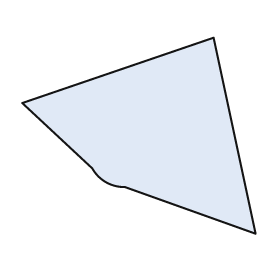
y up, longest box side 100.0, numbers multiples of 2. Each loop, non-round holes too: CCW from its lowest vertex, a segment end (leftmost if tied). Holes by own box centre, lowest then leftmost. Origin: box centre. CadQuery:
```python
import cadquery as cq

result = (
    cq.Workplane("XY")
    .moveTo(50.0, -42.0)
    .lineTo(32.0, 42.0)
    .lineTo(-50.0, 14.0)
    .lineTo(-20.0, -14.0)
    .threePointArc((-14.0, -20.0), (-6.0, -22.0))
    .close()
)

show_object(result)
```